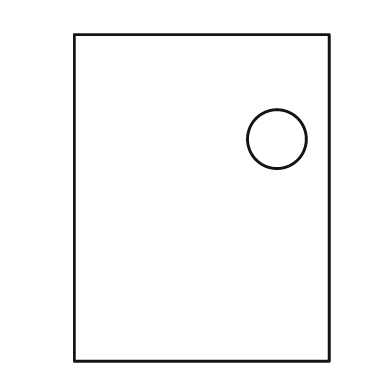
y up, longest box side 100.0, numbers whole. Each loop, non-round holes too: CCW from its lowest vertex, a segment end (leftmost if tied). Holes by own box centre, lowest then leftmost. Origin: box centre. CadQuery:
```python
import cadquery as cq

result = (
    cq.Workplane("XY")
    .moveTo(-39.0, -50.0)
    .lineTo(39.0, -50.0)
    .lineTo(39.0, 50.0)
    .lineTo(-39.0, 50.0)
    .close()
    .moveTo(23.0, 18.0)
    .circle(9.0)
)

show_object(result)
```